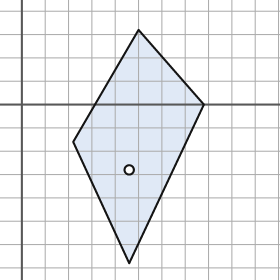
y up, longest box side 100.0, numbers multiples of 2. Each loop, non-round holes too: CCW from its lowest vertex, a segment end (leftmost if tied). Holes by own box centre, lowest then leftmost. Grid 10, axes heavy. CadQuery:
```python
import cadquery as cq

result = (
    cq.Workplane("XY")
    .moveTo(46.0, -68.0)
    .lineTo(78.0, 0.0)
    .lineTo(50.0, 32.0)
    .lineTo(22.0, -16.0)
    .close()
    .moveTo(46.0, -28.0)
    .circle(2.0)
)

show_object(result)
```